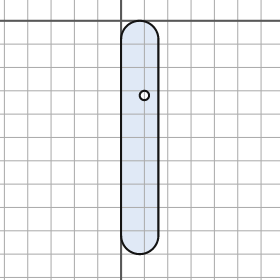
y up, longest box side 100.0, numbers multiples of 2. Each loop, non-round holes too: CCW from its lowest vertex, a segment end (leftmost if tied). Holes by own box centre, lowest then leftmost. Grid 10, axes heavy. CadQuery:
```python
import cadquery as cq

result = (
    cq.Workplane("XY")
    .moveTo(0.0, -92.0)
    .threePointArc((8.0, -100.0), (16.0, -92.0))
    .lineTo(16.0, -8.0)
    .threePointArc((8.0, 0.0), (0.0, -8.0))
    .close()
    .moveTo(10.0, -32.0)
    .circle(2.0)
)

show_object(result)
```